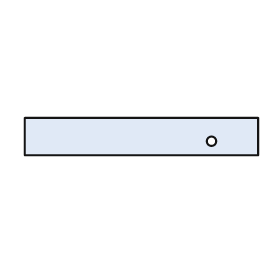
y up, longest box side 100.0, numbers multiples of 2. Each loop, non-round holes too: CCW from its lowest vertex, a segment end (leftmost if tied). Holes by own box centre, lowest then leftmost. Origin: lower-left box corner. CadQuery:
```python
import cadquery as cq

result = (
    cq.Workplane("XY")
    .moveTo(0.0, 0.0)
    .lineTo(100.0, 0.0)
    .lineTo(100.0, 16.0)
    .lineTo(0.0, 16.0)
    .close()
    .moveTo(80.0, 6.0)
    .circle(2.0)
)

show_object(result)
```